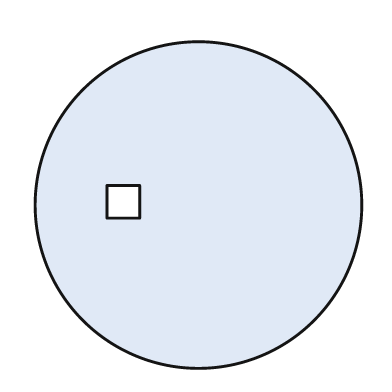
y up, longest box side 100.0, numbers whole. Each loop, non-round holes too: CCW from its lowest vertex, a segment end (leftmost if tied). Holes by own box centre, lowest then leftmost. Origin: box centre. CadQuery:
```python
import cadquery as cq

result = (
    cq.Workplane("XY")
    .moveTo(0.0, 0.0)
    .circle(50.0)
    .moveTo(-28.0, -4.0)
    .lineTo(-18.0, -4.0)
    .lineTo(-18.0, 6.0)
    .lineTo(-28.0, 6.0)
    .close()
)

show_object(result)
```